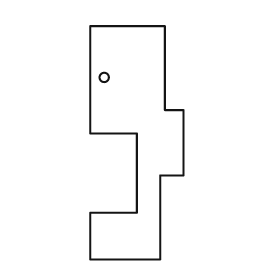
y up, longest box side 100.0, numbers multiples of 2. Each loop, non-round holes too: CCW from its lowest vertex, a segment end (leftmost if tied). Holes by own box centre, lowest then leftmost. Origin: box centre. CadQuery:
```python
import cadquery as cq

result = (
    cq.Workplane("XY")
    .moveTo(-20.0, -50.0)
    .lineTo(10.0, -50.0)
    .lineTo(10.0, -14.0)
    .lineTo(20.0, -14.0)
    .lineTo(20.0, 14.0)
    .lineTo(12.0, 14.0)
    .lineTo(12.0, 50.0)
    .lineTo(-20.0, 50.0)
    .lineTo(-20.0, 4.0)
    .lineTo(0.0, 4.0)
    .lineTo(0.0, -30.0)
    .lineTo(-20.0, -30.0)
    .close()
    .moveTo(-14.0, 28.0)
    .circle(2.0)
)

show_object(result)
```